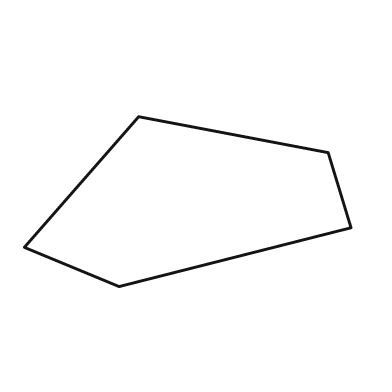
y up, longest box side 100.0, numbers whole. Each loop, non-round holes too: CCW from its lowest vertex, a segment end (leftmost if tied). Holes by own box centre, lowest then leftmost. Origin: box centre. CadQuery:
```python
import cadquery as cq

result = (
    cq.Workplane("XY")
    .moveTo(-21.0, -26.0)
    .lineTo(50.0, -8.0)
    .lineTo(43.0, 15.0)
    .lineTo(-15.0, 26.0)
    .lineTo(-50.0, -14.0)
    .close()
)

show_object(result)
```